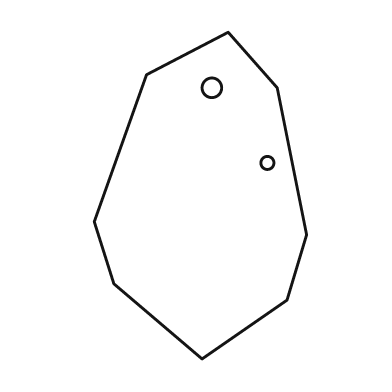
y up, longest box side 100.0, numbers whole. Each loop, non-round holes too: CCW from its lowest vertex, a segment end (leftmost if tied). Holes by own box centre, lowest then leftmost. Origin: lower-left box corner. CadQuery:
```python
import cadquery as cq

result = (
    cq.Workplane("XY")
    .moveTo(33.0, 0.0)
    .lineTo(59.0, 18.0)
    .lineTo(65.0, 38.0)
    .lineTo(56.0, 83.0)
    .lineTo(41.0, 100.0)
    .lineTo(16.0, 87.0)
    .lineTo(0.0, 42.0)
    .lineTo(6.0, 23.0)
    .close()
    .moveTo(53.0, 60.0)
    .circle(2.0)
    .moveTo(36.0, 83.0)
    .circle(3.0)
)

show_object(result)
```